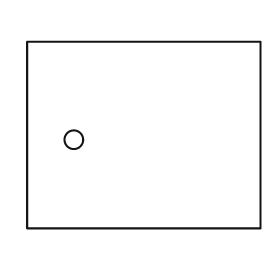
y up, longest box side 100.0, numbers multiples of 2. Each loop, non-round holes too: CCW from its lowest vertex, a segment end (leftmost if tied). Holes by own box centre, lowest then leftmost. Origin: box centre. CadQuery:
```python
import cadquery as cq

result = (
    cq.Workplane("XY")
    .moveTo(-50.0, -40.0)
    .lineTo(50.0, -40.0)
    .lineTo(50.0, 40.0)
    .lineTo(-50.0, 40.0)
    .close()
    .moveTo(-30.0, -2.0)
    .circle(4.0)
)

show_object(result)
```